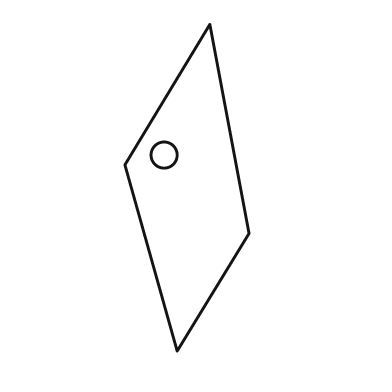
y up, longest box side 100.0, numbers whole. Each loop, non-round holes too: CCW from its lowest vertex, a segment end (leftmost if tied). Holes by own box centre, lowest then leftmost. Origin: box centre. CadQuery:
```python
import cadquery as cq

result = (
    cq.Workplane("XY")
    .moveTo(-3.0, -50.0)
    .lineTo(19.0, -14.0)
    .lineTo(7.0, 50.0)
    .lineTo(-19.0, 7.0)
    .close()
    .moveTo(-7.0, 10.0)
    .circle(4.0)
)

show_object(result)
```